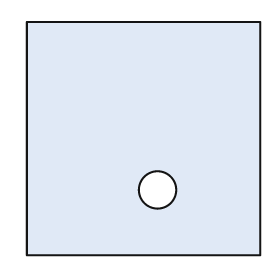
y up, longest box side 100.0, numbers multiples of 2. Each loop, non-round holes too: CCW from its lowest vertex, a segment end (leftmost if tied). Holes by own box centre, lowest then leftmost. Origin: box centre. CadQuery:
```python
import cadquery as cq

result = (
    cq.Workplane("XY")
    .moveTo(-50.0, -50.0)
    .lineTo(50.0, -50.0)
    .lineTo(50.0, 50.0)
    .lineTo(-50.0, 50.0)
    .close()
    .moveTo(6.0, -22.0)
    .circle(8.0)
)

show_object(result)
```